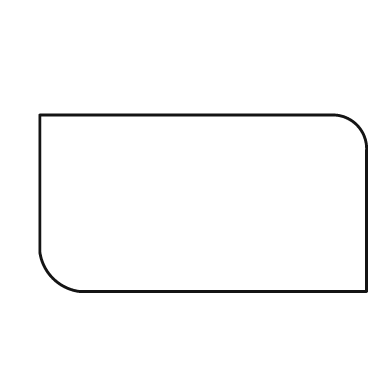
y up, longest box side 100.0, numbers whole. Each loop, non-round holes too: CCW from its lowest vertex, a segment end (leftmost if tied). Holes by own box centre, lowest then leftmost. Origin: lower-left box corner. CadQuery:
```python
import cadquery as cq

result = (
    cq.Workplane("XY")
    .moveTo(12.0, 0.0)
    .lineTo(100.0, 0.0)
    .lineTo(100.0, 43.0)
    .threePointArc((97.0, 51.0), (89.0, 54.0))
    .lineTo(0.0, 54.0)
    .lineTo(0.0, 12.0)
    .threePointArc((4.0, 4.0), (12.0, 0.0))
    .close()
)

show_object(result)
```